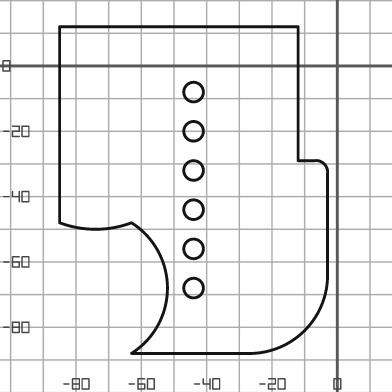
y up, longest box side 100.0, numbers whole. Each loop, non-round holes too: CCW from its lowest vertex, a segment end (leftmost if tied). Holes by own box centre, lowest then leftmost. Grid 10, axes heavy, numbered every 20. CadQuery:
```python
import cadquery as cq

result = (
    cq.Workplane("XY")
    .moveTo(-63.0, -88.0)
    .lineTo(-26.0, -88.0)
    .threePointArc((-10.0, -81.0), (-3.0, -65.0))
    .lineTo(-3.0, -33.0)
    .threePointArc((-4.0, -30.0), (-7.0, -29.0))
    .lineTo(-12.0, -29.0)
    .lineTo(-12.0, 12.0)
    .lineTo(-85.0, 12.0)
    .lineTo(-85.0, -48.0)
    .threePointArc((-74.0, -50.0), (-63.0, -48.0))
    .threePointArc((-52.0, -68.0), (-63.0, -88.0))
    .close()
    .moveTo(-44.0, -68.0)
    .circle(3.0)
    .moveTo(-44.0, -56.0)
    .circle(3.0)
    .moveTo(-44.0, -44.0)
    .circle(3.0)
    .moveTo(-44.0, -32.0)
    .circle(3.0)
    .moveTo(-44.0, -20.0)
    .circle(3.0)
    .moveTo(-44.0, -8.0)
    .circle(3.0)
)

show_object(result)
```